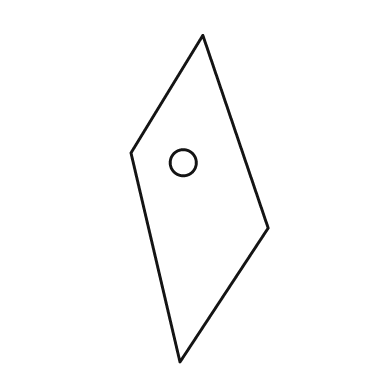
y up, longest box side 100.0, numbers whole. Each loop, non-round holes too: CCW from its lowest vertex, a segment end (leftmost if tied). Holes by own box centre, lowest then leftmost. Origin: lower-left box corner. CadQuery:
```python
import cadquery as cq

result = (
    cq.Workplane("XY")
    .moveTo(15.0, 0.0)
    .lineTo(42.0, 41.0)
    .lineTo(22.0, 100.0)
    .lineTo(0.0, 64.0)
    .close()
    .moveTo(16.0, 61.0)
    .circle(4.0)
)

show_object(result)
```